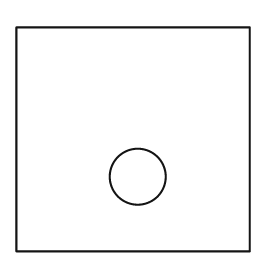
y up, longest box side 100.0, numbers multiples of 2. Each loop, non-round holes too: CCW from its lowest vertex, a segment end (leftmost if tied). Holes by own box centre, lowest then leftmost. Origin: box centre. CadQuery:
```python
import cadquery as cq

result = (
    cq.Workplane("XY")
    .moveTo(-50.0, -48.0)
    .lineTo(50.0, -48.0)
    .lineTo(50.0, 48.0)
    .lineTo(-50.0, 48.0)
    .close()
    .moveTo(2.0, -16.0)
    .circle(12.0)
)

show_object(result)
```